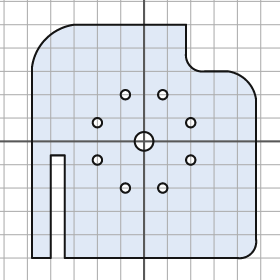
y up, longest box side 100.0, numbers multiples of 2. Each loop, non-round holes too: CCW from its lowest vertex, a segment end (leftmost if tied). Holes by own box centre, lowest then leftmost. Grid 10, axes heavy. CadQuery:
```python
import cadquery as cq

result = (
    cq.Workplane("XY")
    .moveTo(-48.0, -50.0)
    .lineTo(-40.0, -50.0)
    .lineTo(-40.0, -6.0)
    .lineTo(-34.0, -6.0)
    .lineTo(-34.0, -50.0)
    .lineTo(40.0, -50.0)
    .threePointArc((46.0, -48.0), (48.0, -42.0))
    .lineTo(48.0, 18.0)
    .threePointArc((44.0, 26.0), (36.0, 30.0))
    .lineTo(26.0, 30.0)
    .threePointArc((20.0, 32.0), (18.0, 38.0))
    .lineTo(18.0, 50.0)
    .lineTo(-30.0, 50.0)
    .threePointArc((-42.0, 44.0), (-48.0, 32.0))
    .close()
    .moveTo(-8.0, -20.0)
    .circle(2.0)
    .moveTo(8.0, -20.0)
    .circle(2.0)
    .moveTo(-20.0, -8.0)
    .circle(2.0)
    .moveTo(20.0, -8.0)
    .circle(2.0)
    .moveTo(0.0, 0.0)
    .circle(4.0)
    .moveTo(-20.0, 8.0)
    .circle(2.0)
    .moveTo(20.0, 8.0)
    .circle(2.0)
    .moveTo(-8.0, 20.0)
    .circle(2.0)
    .moveTo(8.0, 20.0)
    .circle(2.0)
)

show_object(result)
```